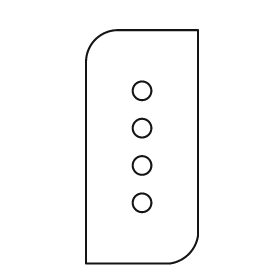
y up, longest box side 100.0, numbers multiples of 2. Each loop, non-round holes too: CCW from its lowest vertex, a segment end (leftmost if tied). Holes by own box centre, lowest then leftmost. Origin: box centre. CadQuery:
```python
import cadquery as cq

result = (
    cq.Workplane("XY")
    .moveTo(-24.0, -50.0)
    .lineTo(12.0, -50.0)
    .threePointArc((20.0, -46.0), (24.0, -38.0))
    .lineTo(24.0, 50.0)
    .lineTo(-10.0, 50.0)
    .threePointArc((-20.0, 46.0), (-24.0, 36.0))
    .close()
    .moveTo(0.0, -24.0)
    .circle(4.0)
    .moveTo(0.0, -8.0)
    .circle(4.0)
    .moveTo(0.0, 8.0)
    .circle(4.0)
    .moveTo(0.0, 24.0)
    .circle(4.0)
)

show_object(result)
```